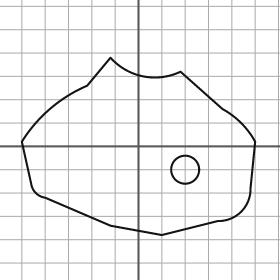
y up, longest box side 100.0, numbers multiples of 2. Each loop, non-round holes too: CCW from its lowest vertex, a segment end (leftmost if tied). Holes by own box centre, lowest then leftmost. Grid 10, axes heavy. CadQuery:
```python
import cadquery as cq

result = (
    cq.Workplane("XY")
    .moveTo(10.0, -38.0)
    .lineTo(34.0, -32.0)
    .threePointArc((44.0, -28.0), (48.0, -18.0))
    .lineTo(50.0, 2.0)
    .threePointArc((44.0, 10.0), (36.0, 16.0))
    .lineTo(18.0, 32.0)
    .threePointArc((2.0, 30.0), (-12.0, 38.0))
    .lineTo(-22.0, 26.0)
    .threePointArc((-38.0, 16.0), (-50.0, 2.0))
    .lineTo(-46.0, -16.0)
    .threePointArc((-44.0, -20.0), (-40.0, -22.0))
    .lineTo(-12.0, -34.0)
    .close()
    .moveTo(20.0, -10.0)
    .circle(6.0)
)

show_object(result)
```